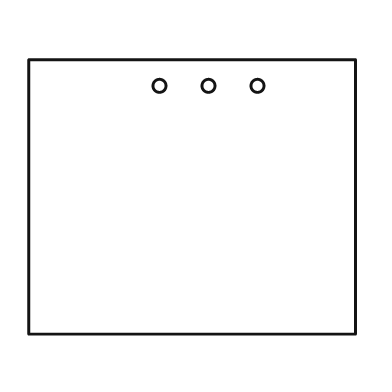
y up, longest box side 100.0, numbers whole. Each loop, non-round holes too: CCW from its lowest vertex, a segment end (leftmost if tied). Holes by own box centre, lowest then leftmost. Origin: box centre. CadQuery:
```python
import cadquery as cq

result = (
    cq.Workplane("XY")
    .moveTo(-50.0, -42.0)
    .lineTo(50.0, -42.0)
    .lineTo(50.0, 42.0)
    .lineTo(-50.0, 42.0)
    .close()
    .moveTo(-10.0, 34.0)
    .circle(2.0)
    .moveTo(5.0, 34.0)
    .circle(2.0)
    .moveTo(20.0, 34.0)
    .circle(2.0)
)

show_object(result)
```